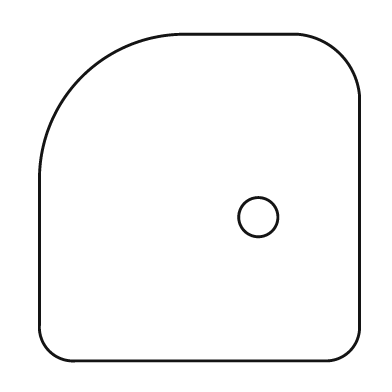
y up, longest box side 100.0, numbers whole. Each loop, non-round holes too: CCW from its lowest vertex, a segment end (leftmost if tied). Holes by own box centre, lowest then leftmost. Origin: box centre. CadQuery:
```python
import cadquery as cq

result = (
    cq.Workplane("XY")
    .moveTo(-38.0, -50.0)
    .lineTo(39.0, -50.0)
    .threePointArc((46.0, -47.0), (49.0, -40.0))
    .lineTo(49.0, 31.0)
    .threePointArc((43.0, 44.0), (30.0, 50.0))
    .lineTo(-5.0, 50.0)
    .threePointArc((-36.0, 37.0), (-49.0, 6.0))
    .lineTo(-49.0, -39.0)
    .threePointArc((-46.0, -47.0), (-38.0, -50.0))
    .close()
    .moveTo(18.0, -6.0)
    .circle(6.0)
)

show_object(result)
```